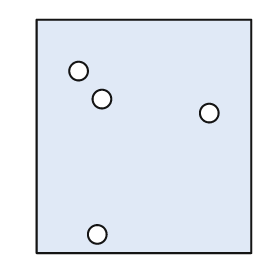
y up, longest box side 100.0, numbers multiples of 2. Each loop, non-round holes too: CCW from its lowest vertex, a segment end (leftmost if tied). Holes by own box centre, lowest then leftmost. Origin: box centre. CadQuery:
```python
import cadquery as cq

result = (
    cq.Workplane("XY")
    .moveTo(-46.0, -50.0)
    .lineTo(46.0, -50.0)
    .lineTo(46.0, 50.0)
    .lineTo(-46.0, 50.0)
    .close()
    .moveTo(-20.0, -42.0)
    .circle(4.0)
    .moveTo(28.0, 10.0)
    .circle(4.0)
    .moveTo(-18.0, 16.0)
    .circle(4.0)
    .moveTo(-28.0, 28.0)
    .circle(4.0)
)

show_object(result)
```